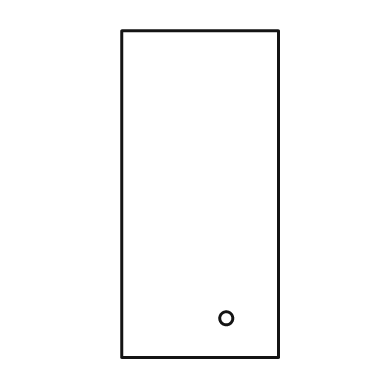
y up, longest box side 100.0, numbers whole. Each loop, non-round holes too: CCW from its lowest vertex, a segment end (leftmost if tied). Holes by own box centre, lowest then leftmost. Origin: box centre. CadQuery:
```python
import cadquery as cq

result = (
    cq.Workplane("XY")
    .moveTo(-24.0, -50.0)
    .lineTo(24.0, -50.0)
    .lineTo(24.0, 50.0)
    .lineTo(-24.0, 50.0)
    .close()
    .moveTo(8.0, -38.0)
    .circle(2.0)
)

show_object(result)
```